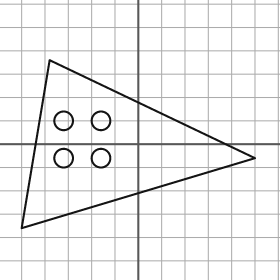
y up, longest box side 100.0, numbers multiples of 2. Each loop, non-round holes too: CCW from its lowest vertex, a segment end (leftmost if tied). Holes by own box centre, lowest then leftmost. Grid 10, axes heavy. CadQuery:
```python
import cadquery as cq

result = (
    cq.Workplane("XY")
    .moveTo(-50.0, -36.0)
    .lineTo(50.0, -6.0)
    .lineTo(-38.0, 36.0)
    .close()
    .moveTo(-32.0, -6.0)
    .circle(4.0)
    .moveTo(-16.0, -6.0)
    .circle(4.0)
    .moveTo(-32.0, 10.0)
    .circle(4.0)
    .moveTo(-16.0, 10.0)
    .circle(4.0)
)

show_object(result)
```